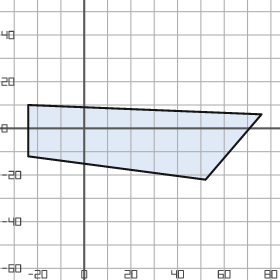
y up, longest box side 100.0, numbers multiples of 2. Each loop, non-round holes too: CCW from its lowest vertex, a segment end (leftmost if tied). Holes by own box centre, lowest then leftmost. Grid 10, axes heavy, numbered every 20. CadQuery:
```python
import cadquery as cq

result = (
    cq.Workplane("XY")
    .moveTo(52.0, -22.0)
    .lineTo(76.0, 6.0)
    .lineTo(-24.0, 10.0)
    .lineTo(-24.0, -12.0)
    .close()
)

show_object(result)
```